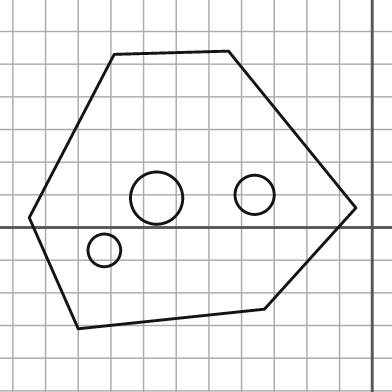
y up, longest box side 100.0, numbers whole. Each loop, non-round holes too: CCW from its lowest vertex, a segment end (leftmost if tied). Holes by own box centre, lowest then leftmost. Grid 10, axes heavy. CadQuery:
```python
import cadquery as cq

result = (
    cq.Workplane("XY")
    .moveTo(-90.0, -31.0)
    .lineTo(-33.0, -25.0)
    .lineTo(-5.0, 6.0)
    .lineTo(-44.0, 54.0)
    .lineTo(-79.0, 53.0)
    .lineTo(-105.0, 3.0)
    .close()
    .moveTo(-82.0, -7.0)
    .circle(5.0)
    .moveTo(-66.0, 9.0)
    .circle(8.0)
    .moveTo(-36.0, 10.0)
    .circle(6.0)
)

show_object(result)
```